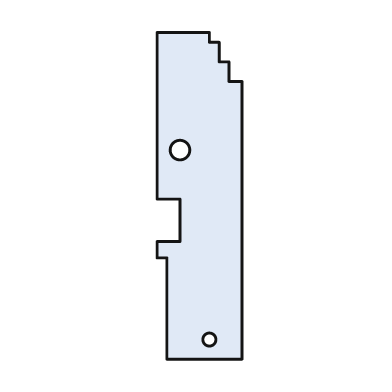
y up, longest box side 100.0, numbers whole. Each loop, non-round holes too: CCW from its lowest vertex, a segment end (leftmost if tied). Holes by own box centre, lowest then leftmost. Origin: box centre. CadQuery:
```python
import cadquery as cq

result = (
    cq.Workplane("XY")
    .moveTo(-10.0, -50.0)
    .lineTo(13.0, -50.0)
    .lineTo(13.0, 35.0)
    .lineTo(9.0, 35.0)
    .lineTo(9.0, 41.0)
    .lineTo(6.0, 41.0)
    .lineTo(6.0, 47.0)
    .lineTo(3.0, 47.0)
    .lineTo(3.0, 50.0)
    .lineTo(-13.0, 50.0)
    .lineTo(-13.0, -1.0)
    .lineTo(-6.0, -1.0)
    .lineTo(-6.0, -14.0)
    .lineTo(-13.0, -14.0)
    .lineTo(-13.0, -19.0)
    .lineTo(-10.0, -19.0)
    .close()
    .moveTo(3.0, -44.0)
    .circle(2.0)
    .moveTo(-6.0, 14.0)
    .circle(3.0)
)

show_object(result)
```